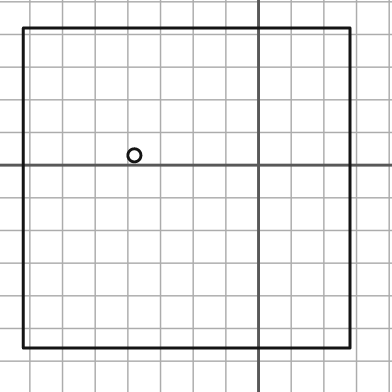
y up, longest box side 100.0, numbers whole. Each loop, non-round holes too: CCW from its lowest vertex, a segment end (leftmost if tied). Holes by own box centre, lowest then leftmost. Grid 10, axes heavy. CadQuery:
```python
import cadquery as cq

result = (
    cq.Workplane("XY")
    .moveTo(-72.0, -56.0)
    .lineTo(28.0, -56.0)
    .lineTo(28.0, 42.0)
    .lineTo(-72.0, 42.0)
    .close()
    .moveTo(-38.0, 3.0)
    .circle(2.0)
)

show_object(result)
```